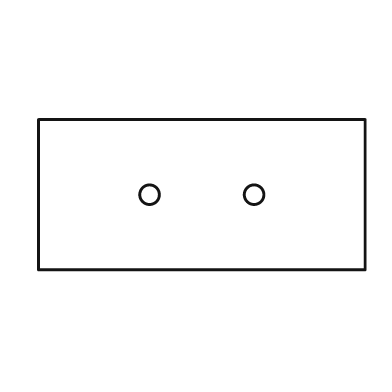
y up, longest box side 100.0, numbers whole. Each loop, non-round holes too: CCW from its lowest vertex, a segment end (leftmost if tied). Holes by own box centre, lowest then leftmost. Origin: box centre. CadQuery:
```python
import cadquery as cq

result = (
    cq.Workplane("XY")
    .moveTo(-50.0, -23.0)
    .lineTo(50.0, -23.0)
    .lineTo(50.0, 23.0)
    .lineTo(-50.0, 23.0)
    .close()
    .moveTo(-16.0, 0.0)
    .circle(3.0)
    .moveTo(16.0, 0.0)
    .circle(3.0)
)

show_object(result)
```